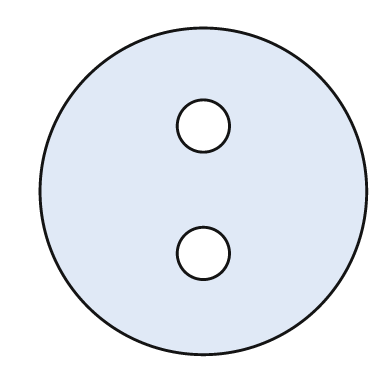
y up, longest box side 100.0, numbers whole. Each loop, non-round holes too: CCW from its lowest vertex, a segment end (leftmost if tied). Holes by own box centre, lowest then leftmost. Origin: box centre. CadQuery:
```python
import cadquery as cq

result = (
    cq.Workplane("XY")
    .moveTo(0.0, 0.0)
    .circle(50.0)
    .moveTo(0.0, -19.0)
    .circle(8.0)
    .moveTo(0.0, 20.0)
    .circle(8.0)
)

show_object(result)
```